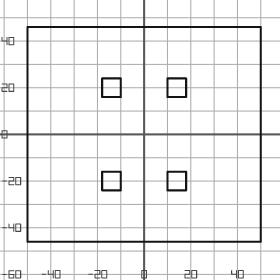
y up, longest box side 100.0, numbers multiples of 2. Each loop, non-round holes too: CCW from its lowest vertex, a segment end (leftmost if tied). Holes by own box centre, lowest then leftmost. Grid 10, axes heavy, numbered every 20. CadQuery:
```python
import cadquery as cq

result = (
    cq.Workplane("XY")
    .moveTo(-50.0, -46.0)
    .lineTo(50.0, -46.0)
    .lineTo(50.0, 46.0)
    .lineTo(-50.0, 46.0)
    .close()
    .moveTo(-18.0, -24.0)
    .lineTo(-10.0, -24.0)
    .lineTo(-10.0, -16.0)
    .lineTo(-18.0, -16.0)
    .close()
    .moveTo(10.0, -24.0)
    .lineTo(18.0, -24.0)
    .lineTo(18.0, -16.0)
    .lineTo(10.0, -16.0)
    .close()
    .moveTo(-18.0, 16.0)
    .lineTo(-10.0, 16.0)
    .lineTo(-10.0, 24.0)
    .lineTo(-18.0, 24.0)
    .close()
    .moveTo(10.0, 16.0)
    .lineTo(18.0, 16.0)
    .lineTo(18.0, 24.0)
    .lineTo(10.0, 24.0)
    .close()
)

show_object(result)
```